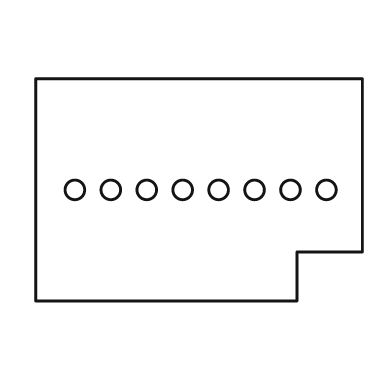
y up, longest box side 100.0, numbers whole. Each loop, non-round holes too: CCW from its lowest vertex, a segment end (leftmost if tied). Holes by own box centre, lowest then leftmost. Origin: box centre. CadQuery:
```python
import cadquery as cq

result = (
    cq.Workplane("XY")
    .moveTo(-50.0, -34.0)
    .lineTo(30.0, -34.0)
    .lineTo(30.0, -19.0)
    .lineTo(50.0, -19.0)
    .lineTo(50.0, 34.0)
    .lineTo(-50.0, 34.0)
    .close()
    .moveTo(-38.0, 0.0)
    .circle(3.0)
    .moveTo(-27.0, 0.0)
    .circle(3.0)
    .moveTo(-16.0, 0.0)
    .circle(3.0)
    .moveTo(-5.0, 0.0)
    .circle(3.0)
    .moveTo(6.0, 0.0)
    .circle(3.0)
    .moveTo(17.0, 0.0)
    .circle(3.0)
    .moveTo(28.0, 0.0)
    .circle(3.0)
    .moveTo(39.0, 0.0)
    .circle(3.0)
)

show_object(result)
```